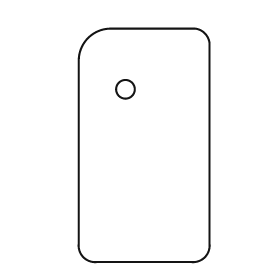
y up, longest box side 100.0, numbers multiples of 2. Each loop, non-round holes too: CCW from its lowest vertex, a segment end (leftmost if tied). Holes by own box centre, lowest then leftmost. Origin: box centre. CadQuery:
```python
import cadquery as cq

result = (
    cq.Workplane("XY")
    .moveTo(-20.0, -50.0)
    .lineTo(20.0, -50.0)
    .threePointArc((26.0, -48.0), (28.0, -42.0))
    .lineTo(28.0, 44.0)
    .threePointArc((26.0, 48.0), (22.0, 50.0))
    .lineTo(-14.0, 50.0)
    .threePointArc((-24.0, 46.0), (-28.0, 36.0))
    .lineTo(-28.0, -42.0)
    .threePointArc((-26.0, -48.0), (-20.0, -50.0))
    .close()
    .moveTo(-8.0, 24.0)
    .circle(4.0)
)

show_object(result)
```